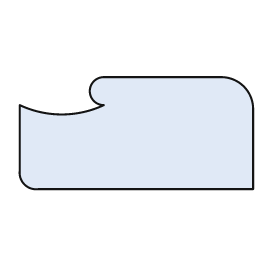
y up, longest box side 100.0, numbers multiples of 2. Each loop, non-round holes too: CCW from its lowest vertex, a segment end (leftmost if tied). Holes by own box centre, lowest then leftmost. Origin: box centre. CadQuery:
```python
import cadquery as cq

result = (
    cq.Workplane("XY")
    .moveTo(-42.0, -24.0)
    .lineTo(50.0, -24.0)
    .lineTo(50.0, 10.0)
    .threePointArc((46.0, 20.0), (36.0, 24.0))
    .lineTo(-14.0, 24.0)
    .threePointArc((-20.0, 18.0), (-14.0, 12.0))
    .threePointArc((-32.0, 8.0), (-50.0, 12.0))
    .lineTo(-50.0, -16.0)
    .threePointArc((-48.0, -22.0), (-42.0, -24.0))
    .close()
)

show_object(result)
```